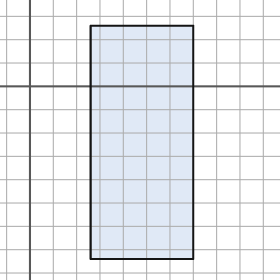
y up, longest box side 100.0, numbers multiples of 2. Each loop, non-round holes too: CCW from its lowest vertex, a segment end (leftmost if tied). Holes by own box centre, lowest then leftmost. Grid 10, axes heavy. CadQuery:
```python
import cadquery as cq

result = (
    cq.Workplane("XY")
    .moveTo(26.0, -74.0)
    .lineTo(70.0, -74.0)
    .lineTo(70.0, 26.0)
    .lineTo(26.0, 26.0)
    .close()
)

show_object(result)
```